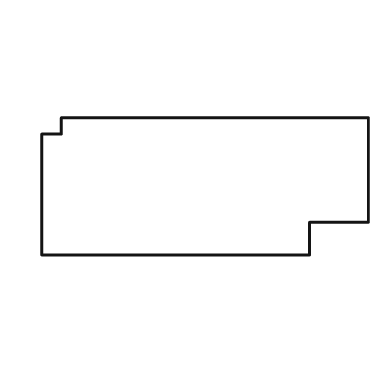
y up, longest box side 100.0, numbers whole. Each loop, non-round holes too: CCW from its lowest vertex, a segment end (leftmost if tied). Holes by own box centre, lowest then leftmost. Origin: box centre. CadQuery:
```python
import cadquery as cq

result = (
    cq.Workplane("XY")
    .moveTo(-50.0, -21.0)
    .lineTo(32.0, -21.0)
    .lineTo(32.0, -11.0)
    .lineTo(50.0, -11.0)
    .lineTo(50.0, 21.0)
    .lineTo(-44.0, 21.0)
    .lineTo(-44.0, 16.0)
    .lineTo(-50.0, 16.0)
    .close()
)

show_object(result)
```